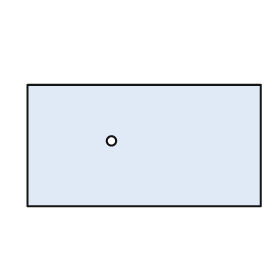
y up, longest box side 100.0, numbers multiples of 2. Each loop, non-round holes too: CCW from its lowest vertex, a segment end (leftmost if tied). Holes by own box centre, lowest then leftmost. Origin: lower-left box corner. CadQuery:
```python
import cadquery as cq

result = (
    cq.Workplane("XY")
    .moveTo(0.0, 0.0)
    .lineTo(100.0, 0.0)
    .lineTo(100.0, 52.0)
    .lineTo(0.0, 52.0)
    .close()
    .moveTo(36.0, 28.0)
    .circle(2.0)
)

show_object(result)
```